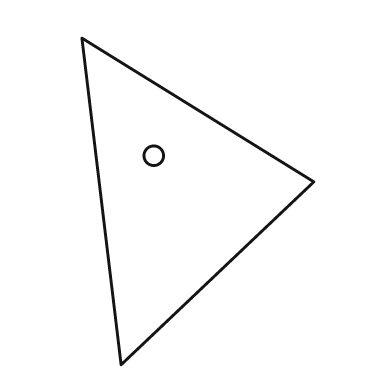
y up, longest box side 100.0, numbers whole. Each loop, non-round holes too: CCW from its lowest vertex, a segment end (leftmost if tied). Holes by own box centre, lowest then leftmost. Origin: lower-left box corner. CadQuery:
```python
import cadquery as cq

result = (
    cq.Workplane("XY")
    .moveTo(12.0, 0.0)
    .lineTo(71.0, 56.0)
    .lineTo(0.0, 100.0)
    .close()
    .moveTo(22.0, 64.0)
    .circle(3.0)
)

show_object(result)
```